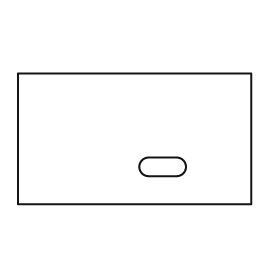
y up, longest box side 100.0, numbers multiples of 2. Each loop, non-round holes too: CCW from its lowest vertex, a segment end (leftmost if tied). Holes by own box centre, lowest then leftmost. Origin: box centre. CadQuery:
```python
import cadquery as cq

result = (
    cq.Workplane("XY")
    .moveTo(-50.0, -28.0)
    .lineTo(50.0, -28.0)
    .lineTo(50.0, 28.0)
    .lineTo(-50.0, 28.0)
    .close()
    .moveTo(6.0, -16.0)
    .lineTo(18.0, -16.0)
    .threePointArc((22.0, -12.0), (18.0, -8.0))
    .lineTo(6.0, -8.0)
    .threePointArc((2.0, -12.0), (6.0, -16.0))
    .close()
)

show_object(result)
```